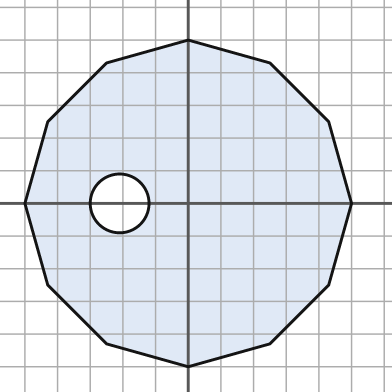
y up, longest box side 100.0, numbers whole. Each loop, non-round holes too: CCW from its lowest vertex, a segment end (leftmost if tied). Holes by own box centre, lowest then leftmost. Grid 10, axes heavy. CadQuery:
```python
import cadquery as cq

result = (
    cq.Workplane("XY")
    .moveTo(0.0, -50.0)
    .lineTo(25.0, -43.0)
    .lineTo(43.0, -25.0)
    .lineTo(50.0, 0.0)
    .lineTo(43.0, 25.0)
    .lineTo(25.0, 43.0)
    .lineTo(0.0, 50.0)
    .lineTo(-25.0, 43.0)
    .lineTo(-43.0, 25.0)
    .lineTo(-50.0, 0.0)
    .lineTo(-43.0, -25.0)
    .lineTo(-25.0, -43.0)
    .close()
    .moveTo(-21.0, 0.0)
    .circle(9.0)
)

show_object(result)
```